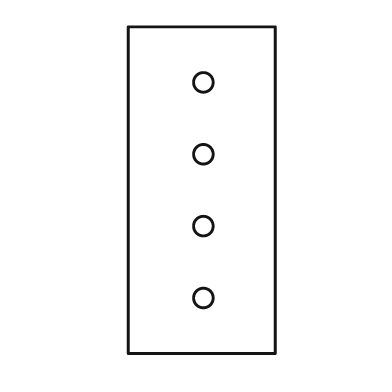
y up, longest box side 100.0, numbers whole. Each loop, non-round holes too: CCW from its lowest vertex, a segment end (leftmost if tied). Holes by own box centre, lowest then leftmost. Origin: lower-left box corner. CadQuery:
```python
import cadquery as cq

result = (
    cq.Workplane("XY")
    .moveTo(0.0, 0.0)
    .lineTo(45.0, 0.0)
    .lineTo(45.0, 100.0)
    .lineTo(0.0, 100.0)
    .close()
    .moveTo(23.0, 17.0)
    .circle(3.0)
    .moveTo(23.0, 39.0)
    .circle(3.0)
    .moveTo(23.0, 61.0)
    .circle(3.0)
    .moveTo(23.0, 83.0)
    .circle(3.0)
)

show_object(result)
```